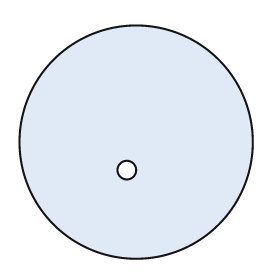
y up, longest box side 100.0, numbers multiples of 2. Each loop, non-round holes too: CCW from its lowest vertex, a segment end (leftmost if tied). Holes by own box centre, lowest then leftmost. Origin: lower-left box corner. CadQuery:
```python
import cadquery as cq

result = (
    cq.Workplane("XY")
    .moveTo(50.0, 50.0)
    .circle(50.0)
    .moveTo(46.0, 38.0)
    .circle(4.0)
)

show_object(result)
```